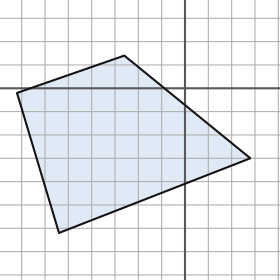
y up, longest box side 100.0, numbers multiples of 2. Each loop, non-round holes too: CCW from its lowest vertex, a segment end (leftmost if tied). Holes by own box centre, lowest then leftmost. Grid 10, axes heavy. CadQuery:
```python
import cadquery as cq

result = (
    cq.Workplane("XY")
    .moveTo(-54.0, -62.0)
    .lineTo(28.0, -30.0)
    .lineTo(-26.0, 14.0)
    .lineTo(-72.0, -2.0)
    .close()
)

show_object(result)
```